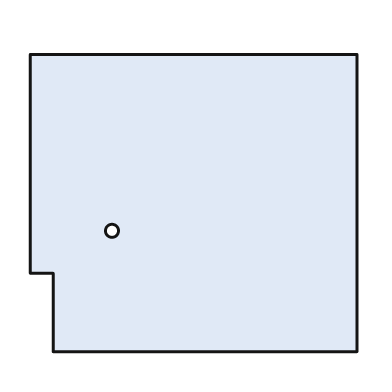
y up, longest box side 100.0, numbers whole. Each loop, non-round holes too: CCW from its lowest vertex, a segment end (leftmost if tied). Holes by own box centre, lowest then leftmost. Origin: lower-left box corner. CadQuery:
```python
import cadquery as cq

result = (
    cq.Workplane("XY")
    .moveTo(7.0, 0.0)
    .lineTo(100.0, 0.0)
    .lineTo(100.0, 91.0)
    .lineTo(0.0, 91.0)
    .lineTo(0.0, 24.0)
    .lineTo(7.0, 24.0)
    .close()
    .moveTo(25.0, 37.0)
    .circle(2.0)
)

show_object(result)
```